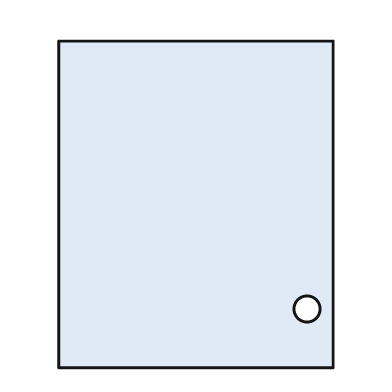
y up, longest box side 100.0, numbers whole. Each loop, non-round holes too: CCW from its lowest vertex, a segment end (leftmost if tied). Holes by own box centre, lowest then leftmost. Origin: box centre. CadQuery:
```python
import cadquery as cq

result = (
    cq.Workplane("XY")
    .moveTo(-42.0, -50.0)
    .lineTo(42.0, -50.0)
    .lineTo(42.0, 50.0)
    .lineTo(-42.0, 50.0)
    .close()
    .moveTo(34.0, -32.0)
    .circle(4.0)
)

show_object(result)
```